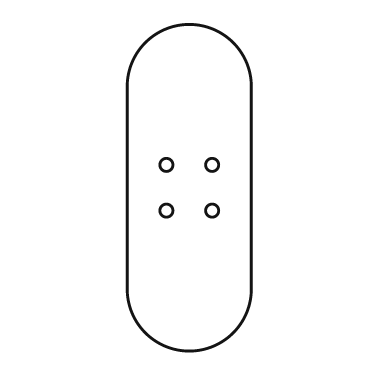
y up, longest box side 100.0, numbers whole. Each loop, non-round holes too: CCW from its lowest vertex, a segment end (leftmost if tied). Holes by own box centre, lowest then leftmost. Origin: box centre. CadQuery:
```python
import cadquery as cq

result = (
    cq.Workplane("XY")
    .moveTo(-19.0, -31.0)
    .threePointArc((0.0, -50.0), (19.0, -31.0))
    .lineTo(19.0, 31.0)
    .threePointArc((0.0, 50.0), (-19.0, 31.0))
    .close()
    .moveTo(-7.0, -7.0)
    .circle(2.0)
    .moveTo(7.0, -7.0)
    .circle(2.0)
    .moveTo(-7.0, 7.0)
    .circle(2.0)
    .moveTo(7.0, 7.0)
    .circle(2.0)
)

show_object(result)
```